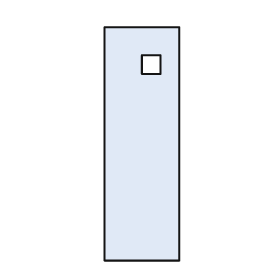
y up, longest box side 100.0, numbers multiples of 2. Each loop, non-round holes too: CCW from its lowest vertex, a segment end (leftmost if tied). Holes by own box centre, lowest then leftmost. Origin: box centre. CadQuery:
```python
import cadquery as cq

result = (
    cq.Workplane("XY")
    .moveTo(-16.0, -50.0)
    .lineTo(16.0, -50.0)
    .lineTo(16.0, 50.0)
    .lineTo(-16.0, 50.0)
    .close()
    .moveTo(0.0, 30.0)
    .lineTo(8.0, 30.0)
    .lineTo(8.0, 38.0)
    .lineTo(0.0, 38.0)
    .close()
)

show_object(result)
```